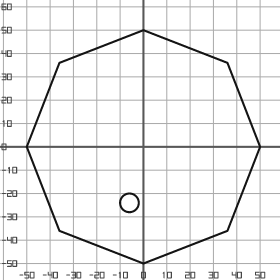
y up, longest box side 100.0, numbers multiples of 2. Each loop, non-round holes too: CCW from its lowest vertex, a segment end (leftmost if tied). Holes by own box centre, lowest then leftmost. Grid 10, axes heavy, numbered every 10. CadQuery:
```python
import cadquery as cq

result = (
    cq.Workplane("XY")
    .moveTo(0.0, -50.0)
    .lineTo(36.0, -36.0)
    .lineTo(50.0, 0.0)
    .lineTo(36.0, 36.0)
    .lineTo(0.0, 50.0)
    .lineTo(-36.0, 36.0)
    .lineTo(-50.0, 0.0)
    .lineTo(-36.0, -36.0)
    .close()
    .moveTo(-6.0, -24.0)
    .circle(4.0)
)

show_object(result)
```